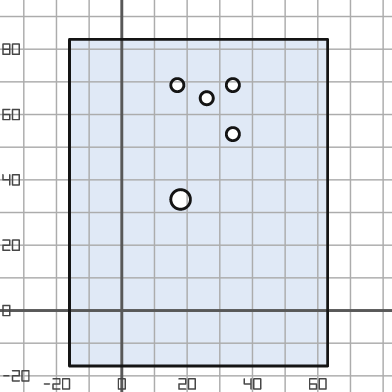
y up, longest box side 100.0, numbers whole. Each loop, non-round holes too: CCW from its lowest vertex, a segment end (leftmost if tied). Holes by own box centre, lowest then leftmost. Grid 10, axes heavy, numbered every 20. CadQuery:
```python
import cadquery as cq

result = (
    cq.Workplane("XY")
    .moveTo(-16.0, -17.0)
    .lineTo(63.0, -17.0)
    .lineTo(63.0, 83.0)
    .lineTo(-16.0, 83.0)
    .close()
    .moveTo(18.0, 34.0)
    .circle(3.0)
    .moveTo(34.0, 54.0)
    .circle(2.0)
    .moveTo(26.0, 65.0)
    .circle(2.0)
    .moveTo(17.0, 69.0)
    .circle(2.0)
    .moveTo(34.0, 69.0)
    .circle(2.0)
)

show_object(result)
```